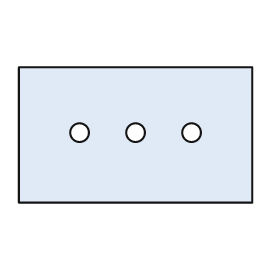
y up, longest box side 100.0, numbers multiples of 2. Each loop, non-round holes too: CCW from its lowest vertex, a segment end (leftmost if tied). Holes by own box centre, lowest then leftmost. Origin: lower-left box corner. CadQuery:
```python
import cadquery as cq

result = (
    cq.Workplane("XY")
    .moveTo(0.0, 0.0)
    .lineTo(100.0, 0.0)
    .lineTo(100.0, 58.0)
    .lineTo(0.0, 58.0)
    .close()
    .moveTo(26.0, 30.0)
    .circle(4.0)
    .moveTo(50.0, 30.0)
    .circle(4.0)
    .moveTo(74.0, 30.0)
    .circle(4.0)
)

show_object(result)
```